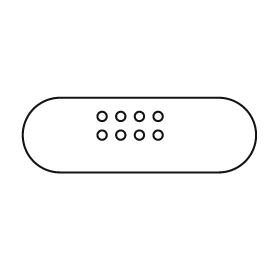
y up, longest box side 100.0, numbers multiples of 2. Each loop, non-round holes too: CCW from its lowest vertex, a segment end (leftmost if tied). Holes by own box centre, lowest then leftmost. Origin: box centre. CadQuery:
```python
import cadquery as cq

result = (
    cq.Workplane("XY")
    .moveTo(-34.0, -16.0)
    .lineTo(34.0, -16.0)
    .threePointArc((50.0, 0.0), (34.0, 16.0))
    .lineTo(-34.0, 16.0)
    .threePointArc((-50.0, 0.0), (-34.0, -16.0))
    .close()
    .moveTo(-16.0, 0.0)
    .circle(2.0)
    .moveTo(-8.0, 0.0)
    .circle(2.0)
    .moveTo(0.0, 0.0)
    .circle(2.0)
    .moveTo(8.0, 0.0)
    .circle(2.0)
    .moveTo(-16.0, 8.0)
    .circle(2.0)
    .moveTo(-8.0, 8.0)
    .circle(2.0)
    .moveTo(0.0, 8.0)
    .circle(2.0)
    .moveTo(8.0, 8.0)
    .circle(2.0)
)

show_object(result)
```